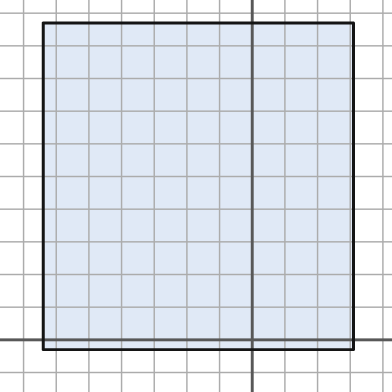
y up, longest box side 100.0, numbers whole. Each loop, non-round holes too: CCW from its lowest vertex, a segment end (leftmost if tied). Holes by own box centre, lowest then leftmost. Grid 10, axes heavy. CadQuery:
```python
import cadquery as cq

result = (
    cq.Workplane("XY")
    .moveTo(-64.0, -3.0)
    .lineTo(31.0, -3.0)
    .lineTo(31.0, 97.0)
    .lineTo(-64.0, 97.0)
    .close()
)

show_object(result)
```